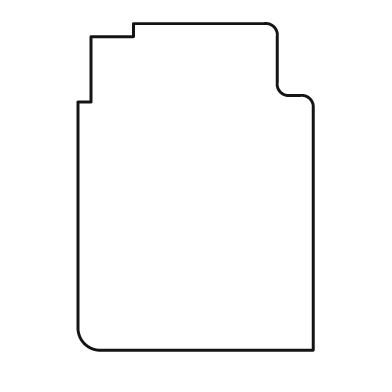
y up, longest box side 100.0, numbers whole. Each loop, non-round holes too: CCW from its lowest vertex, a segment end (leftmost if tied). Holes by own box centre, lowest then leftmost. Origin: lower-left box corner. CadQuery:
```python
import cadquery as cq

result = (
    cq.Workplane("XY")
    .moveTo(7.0, 0.0)
    .lineTo(72.0, 0.0)
    .lineTo(72.0, 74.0)
    .threePointArc((71.0, 77.0), (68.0, 78.0))
    .lineTo(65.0, 78.0)
    .threePointArc((62.0, 79.0), (61.0, 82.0))
    .lineTo(61.0, 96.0)
    .threePointArc((60.0, 99.0), (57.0, 100.0))
    .lineTo(17.0, 100.0)
    .lineTo(17.0, 96.0)
    .lineTo(4.0, 96.0)
    .lineTo(4.0, 76.0)
    .lineTo(0.0, 76.0)
    .lineTo(0.0, 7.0)
    .threePointArc((2.0, 2.0), (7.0, 0.0))
    .close()
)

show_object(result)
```